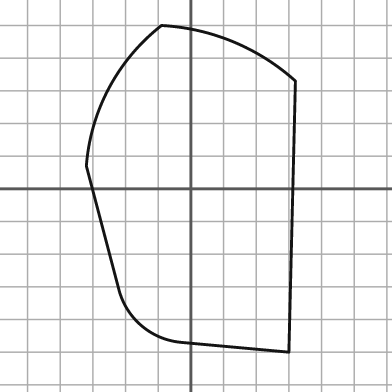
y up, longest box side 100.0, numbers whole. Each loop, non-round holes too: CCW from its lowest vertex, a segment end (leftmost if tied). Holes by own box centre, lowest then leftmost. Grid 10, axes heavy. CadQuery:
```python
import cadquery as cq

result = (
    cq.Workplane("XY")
    .moveTo(30.0, -50.0)
    .lineTo(32.0, 33.0)
    .threePointArc((13.0, 45.0), (-9.0, 50.0))
    .threePointArc((-25.0, 31.0), (-32.0, 7.0))
    .lineTo(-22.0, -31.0)
    .threePointArc((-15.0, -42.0), (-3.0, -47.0))
    .close()
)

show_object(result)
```